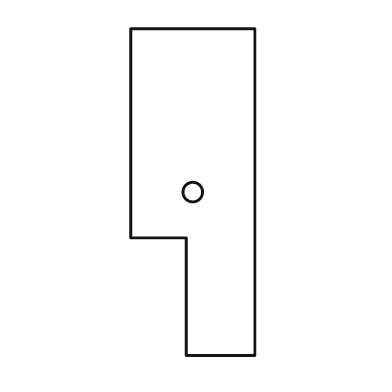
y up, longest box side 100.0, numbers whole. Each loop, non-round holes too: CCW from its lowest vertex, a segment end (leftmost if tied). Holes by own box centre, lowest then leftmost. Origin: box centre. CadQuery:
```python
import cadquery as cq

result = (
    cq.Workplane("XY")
    .moveTo(-2.0, -50.0)
    .lineTo(19.0, -50.0)
    .lineTo(19.0, 50.0)
    .lineTo(-19.0, 50.0)
    .lineTo(-19.0, -14.0)
    .lineTo(-2.0, -14.0)
    .close()
    .moveTo(0.0, 0.0)
    .circle(3.0)
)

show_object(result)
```